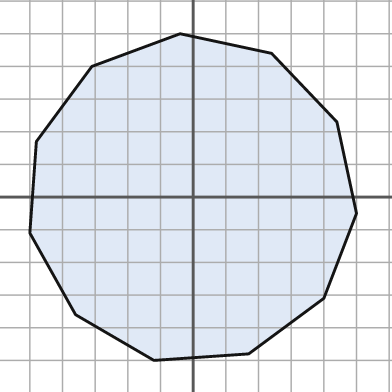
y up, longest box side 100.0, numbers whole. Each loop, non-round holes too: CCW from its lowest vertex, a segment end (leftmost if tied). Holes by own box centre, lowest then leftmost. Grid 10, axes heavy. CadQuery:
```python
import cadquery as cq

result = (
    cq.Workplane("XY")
    .moveTo(-12.0, -50.0)
    .lineTo(17.0, -48.0)
    .lineTo(40.0, -31.0)
    .lineTo(50.0, -5.0)
    .lineTo(44.0, 23.0)
    .lineTo(24.0, 44.0)
    .lineTo(-4.0, 50.0)
    .lineTo(-31.0, 40.0)
    .lineTo(-48.0, 17.0)
    .lineTo(-50.0, -11.0)
    .lineTo(-36.0, -36.0)
    .close()
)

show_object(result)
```